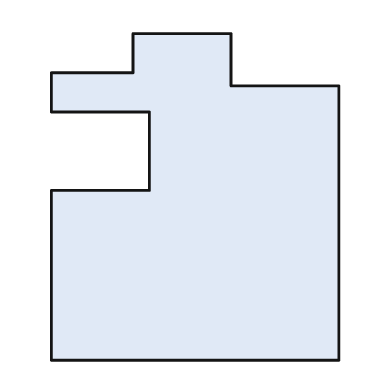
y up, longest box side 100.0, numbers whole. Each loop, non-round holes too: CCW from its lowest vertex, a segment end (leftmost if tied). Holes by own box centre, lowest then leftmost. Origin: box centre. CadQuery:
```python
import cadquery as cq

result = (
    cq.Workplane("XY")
    .moveTo(-44.0, -50.0)
    .lineTo(44.0, -50.0)
    .lineTo(44.0, 34.0)
    .lineTo(11.0, 34.0)
    .lineTo(11.0, 50.0)
    .lineTo(-19.0, 50.0)
    .lineTo(-19.0, 38.0)
    .lineTo(-44.0, 38.0)
    .lineTo(-44.0, 26.0)
    .lineTo(-14.0, 26.0)
    .lineTo(-14.0, 2.0)
    .lineTo(-44.0, 2.0)
    .close()
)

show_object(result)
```